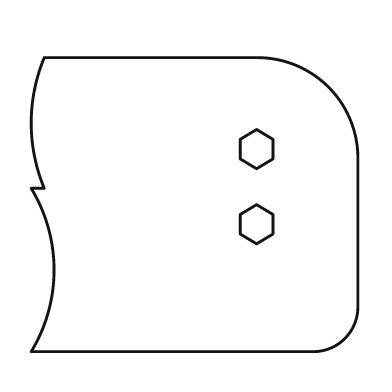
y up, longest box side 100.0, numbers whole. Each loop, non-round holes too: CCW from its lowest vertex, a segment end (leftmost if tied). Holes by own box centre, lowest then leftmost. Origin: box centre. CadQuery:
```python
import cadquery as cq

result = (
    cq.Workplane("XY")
    .moveTo(-50.0, -45.0)
    .lineTo(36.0, -45.0)
    .threePointArc((46.0, -41.0), (50.0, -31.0))
    .lineTo(50.0, 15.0)
    .threePointArc((41.0, 36.0), (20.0, 45.0))
    .lineTo(-46.0, 45.0)
    .threePointArc((-50.0, 25.0), (-46.0, 5.0))
    .lineTo(-50.0, 5.0)
    .threePointArc((-43.0, -20.0), (-50.0, -45.0))
    .close()
    .moveTo(19.0, -12.0)
    .lineTo(24.0, -9.0)
    .lineTo(24.0, -3.0)
    .lineTo(19.0, 0.0)
    .lineTo(14.0, -3.0)
    .lineTo(14.0, -9.0)
    .close()
    .moveTo(19.0, 11.0)
    .lineTo(24.0, 14.0)
    .lineTo(24.0, 20.0)
    .lineTo(19.0, 23.0)
    .lineTo(14.0, 20.0)
    .lineTo(14.0, 14.0)
    .close()
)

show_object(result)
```